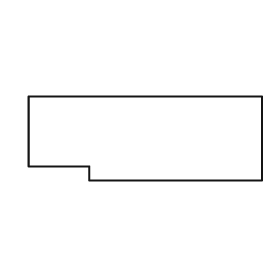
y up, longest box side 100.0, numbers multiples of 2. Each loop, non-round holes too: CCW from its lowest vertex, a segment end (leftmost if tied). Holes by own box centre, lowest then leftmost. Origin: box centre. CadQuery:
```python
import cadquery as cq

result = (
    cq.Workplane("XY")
    .moveTo(-24.0, -18.0)
    .lineTo(50.0, -18.0)
    .lineTo(50.0, 18.0)
    .lineTo(-50.0, 18.0)
    .lineTo(-50.0, -12.0)
    .lineTo(-24.0, -12.0)
    .close()
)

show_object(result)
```